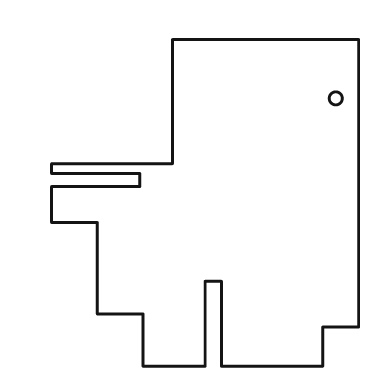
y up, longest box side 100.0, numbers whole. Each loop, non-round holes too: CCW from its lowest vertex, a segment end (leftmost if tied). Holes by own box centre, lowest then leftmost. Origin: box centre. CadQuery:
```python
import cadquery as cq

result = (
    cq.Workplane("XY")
    .moveTo(-19.0, -50.0)
    .lineTo(0.0, -50.0)
    .lineTo(0.0, -24.0)
    .lineTo(5.0, -24.0)
    .lineTo(5.0, -50.0)
    .lineTo(36.0, -50.0)
    .lineTo(36.0, -38.0)
    .lineTo(47.0, -38.0)
    .lineTo(47.0, 50.0)
    .lineTo(-10.0, 50.0)
    .lineTo(-10.0, 12.0)
    .lineTo(-47.0, 12.0)
    .lineTo(-47.0, 9.0)
    .lineTo(-20.0, 9.0)
    .lineTo(-20.0, 5.0)
    .lineTo(-47.0, 5.0)
    .lineTo(-47.0, -6.0)
    .lineTo(-33.0, -6.0)
    .lineTo(-33.0, -34.0)
    .lineTo(-19.0, -34.0)
    .close()
    .moveTo(40.0, 32.0)
    .circle(2.0)
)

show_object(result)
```